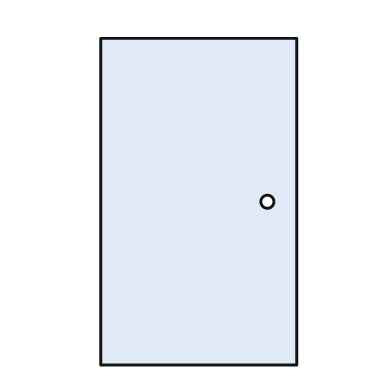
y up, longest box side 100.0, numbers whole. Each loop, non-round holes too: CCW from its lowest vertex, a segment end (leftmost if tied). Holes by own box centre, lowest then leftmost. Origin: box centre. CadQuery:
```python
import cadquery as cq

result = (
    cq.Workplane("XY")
    .moveTo(-30.0, -50.0)
    .lineTo(30.0, -50.0)
    .lineTo(30.0, 50.0)
    .lineTo(-30.0, 50.0)
    .close()
    .moveTo(21.0, 0.0)
    .circle(2.0)
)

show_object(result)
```